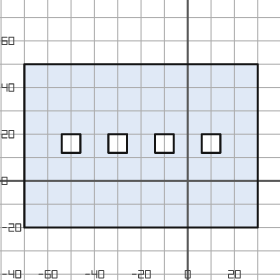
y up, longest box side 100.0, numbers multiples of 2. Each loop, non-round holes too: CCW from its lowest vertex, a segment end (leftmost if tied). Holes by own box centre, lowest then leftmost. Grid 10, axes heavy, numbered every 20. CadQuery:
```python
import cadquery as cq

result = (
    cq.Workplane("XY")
    .moveTo(-70.0, -20.0)
    .lineTo(30.0, -20.0)
    .lineTo(30.0, 50.0)
    .lineTo(-70.0, 50.0)
    .close()
    .moveTo(-54.0, 12.0)
    .lineTo(-46.0, 12.0)
    .lineTo(-46.0, 20.0)
    .lineTo(-54.0, 20.0)
    .close()
    .moveTo(-34.0, 12.0)
    .lineTo(-26.0, 12.0)
    .lineTo(-26.0, 20.0)
    .lineTo(-34.0, 20.0)
    .close()
    .moveTo(-14.0, 12.0)
    .lineTo(-6.0, 12.0)
    .lineTo(-6.0, 20.0)
    .lineTo(-14.0, 20.0)
    .close()
    .moveTo(6.0, 12.0)
    .lineTo(14.0, 12.0)
    .lineTo(14.0, 20.0)
    .lineTo(6.0, 20.0)
    .close()
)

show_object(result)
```